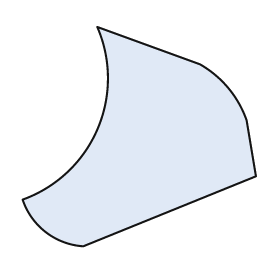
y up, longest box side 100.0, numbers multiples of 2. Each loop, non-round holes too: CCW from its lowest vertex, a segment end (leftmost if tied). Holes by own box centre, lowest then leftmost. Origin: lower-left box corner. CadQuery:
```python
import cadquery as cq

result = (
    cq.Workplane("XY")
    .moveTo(26.0, 0.0)
    .lineTo(100.0, 30.0)
    .lineTo(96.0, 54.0)
    .threePointArc((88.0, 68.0), (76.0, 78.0))
    .lineTo(32.0, 94.0)
    .threePointArc((32.0, 50.0), (0.0, 20.0))
    .threePointArc((10.0, 6.0), (26.0, 0.0))
    .close()
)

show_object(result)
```